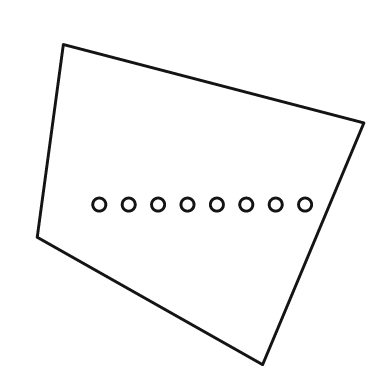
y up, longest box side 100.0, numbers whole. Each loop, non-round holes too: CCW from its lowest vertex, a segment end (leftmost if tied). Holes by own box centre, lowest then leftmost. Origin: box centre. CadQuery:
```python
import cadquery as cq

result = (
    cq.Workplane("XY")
    .moveTo(19.0, -49.0)
    .lineTo(50.0, 25.0)
    .lineTo(-42.0, 49.0)
    .lineTo(-50.0, -10.0)
    .close()
    .moveTo(-31.0, 0.0)
    .circle(2.0)
    .moveTo(-22.0, 0.0)
    .circle(2.0)
    .moveTo(-13.0, 0.0)
    .circle(2.0)
    .moveTo(-4.0, 0.0)
    .circle(2.0)
    .moveTo(5.0, 0.0)
    .circle(2.0)
    .moveTo(14.0, 0.0)
    .circle(2.0)
    .moveTo(23.0, 0.0)
    .circle(2.0)
    .moveTo(32.0, 0.0)
    .circle(2.0)
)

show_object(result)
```